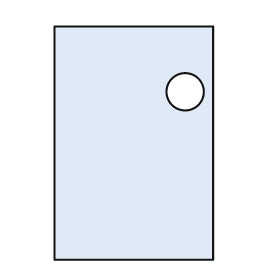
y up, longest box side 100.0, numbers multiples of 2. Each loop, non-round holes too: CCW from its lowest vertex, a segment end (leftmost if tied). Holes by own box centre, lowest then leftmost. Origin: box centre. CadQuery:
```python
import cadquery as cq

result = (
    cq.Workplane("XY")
    .moveTo(-34.0, -50.0)
    .lineTo(34.0, -50.0)
    .lineTo(34.0, 50.0)
    .lineTo(-34.0, 50.0)
    .close()
    .moveTo(22.0, 22.0)
    .circle(8.0)
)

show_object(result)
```